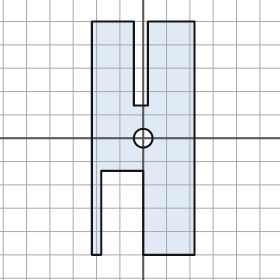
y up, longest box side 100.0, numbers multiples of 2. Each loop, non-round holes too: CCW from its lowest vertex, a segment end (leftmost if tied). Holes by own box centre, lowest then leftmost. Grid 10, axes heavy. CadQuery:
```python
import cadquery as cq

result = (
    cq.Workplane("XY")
    .moveTo(-22.0, -50.0)
    .lineTo(-18.0, -50.0)
    .lineTo(-18.0, -14.0)
    .lineTo(0.0, -14.0)
    .lineTo(0.0, -50.0)
    .lineTo(22.0, -50.0)
    .lineTo(22.0, 50.0)
    .lineTo(2.0, 50.0)
    .lineTo(2.0, 14.0)
    .lineTo(-4.0, 14.0)
    .lineTo(-4.0, 50.0)
    .lineTo(-22.0, 50.0)
    .close()
    .moveTo(0.0, 0.0)
    .circle(4.0)
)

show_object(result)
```